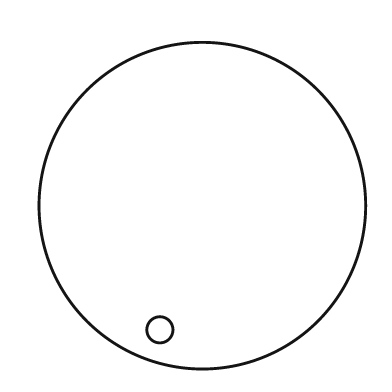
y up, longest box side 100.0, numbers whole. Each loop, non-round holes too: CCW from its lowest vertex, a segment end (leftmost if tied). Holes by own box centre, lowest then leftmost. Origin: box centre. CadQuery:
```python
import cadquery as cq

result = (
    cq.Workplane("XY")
    .moveTo(0.0, 0.0)
    .circle(50.0)
    .moveTo(-13.0, -38.0)
    .circle(4.0)
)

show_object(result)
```